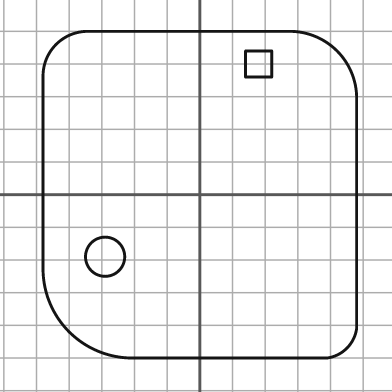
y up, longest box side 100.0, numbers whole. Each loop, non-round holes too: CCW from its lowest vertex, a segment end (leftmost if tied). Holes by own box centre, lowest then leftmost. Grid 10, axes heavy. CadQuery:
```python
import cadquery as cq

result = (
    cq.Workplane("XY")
    .moveTo(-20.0, -50.0)
    .lineTo(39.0, -50.0)
    .threePointArc((45.0, -47.0), (48.0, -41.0))
    .lineTo(48.0, 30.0)
    .threePointArc((42.0, 44.0), (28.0, 50.0))
    .lineTo(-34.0, 50.0)
    .threePointArc((-44.0, 46.0), (-48.0, 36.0))
    .lineTo(-48.0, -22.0)
    .threePointArc((-40.0, -42.0), (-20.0, -50.0))
    .close()
    .moveTo(-29.0, -19.0)
    .circle(6.0)
    .moveTo(14.0, 36.0)
    .lineTo(22.0, 36.0)
    .lineTo(22.0, 44.0)
    .lineTo(14.0, 44.0)
    .close()
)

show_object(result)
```